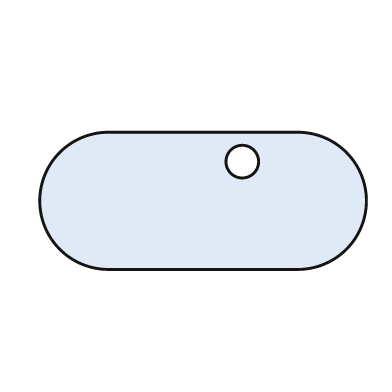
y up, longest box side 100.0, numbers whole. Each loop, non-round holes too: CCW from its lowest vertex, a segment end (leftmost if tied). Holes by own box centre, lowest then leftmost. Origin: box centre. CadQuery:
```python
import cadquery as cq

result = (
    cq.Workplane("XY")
    .moveTo(-29.0, -21.0)
    .lineTo(29.0, -21.0)
    .threePointArc((50.0, 0.0), (29.0, 21.0))
    .lineTo(-29.0, 21.0)
    .threePointArc((-50.0, 0.0), (-29.0, -21.0))
    .close()
    .moveTo(12.0, 12.0)
    .circle(5.0)
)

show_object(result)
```